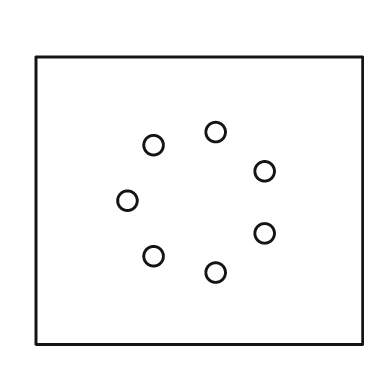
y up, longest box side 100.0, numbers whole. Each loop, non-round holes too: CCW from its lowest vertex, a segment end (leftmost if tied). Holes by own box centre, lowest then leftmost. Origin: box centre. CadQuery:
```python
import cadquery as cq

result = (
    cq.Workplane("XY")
    .moveTo(-50.0, -44.0)
    .lineTo(50.0, -44.0)
    .lineTo(50.0, 44.0)
    .lineTo(-50.0, 44.0)
    .close()
    .moveTo(5.0, -22.0)
    .circle(3.0)
    .moveTo(-14.0, -17.0)
    .circle(3.0)
    .moveTo(20.0, -10.0)
    .circle(3.0)
    .moveTo(-22.0, 0.0)
    .circle(3.0)
    .moveTo(20.0, 9.0)
    .circle(3.0)
    .moveTo(-14.0, 17.0)
    .circle(3.0)
    .moveTo(5.0, 21.0)
    .circle(3.0)
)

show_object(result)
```